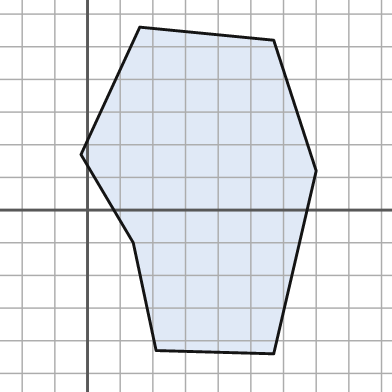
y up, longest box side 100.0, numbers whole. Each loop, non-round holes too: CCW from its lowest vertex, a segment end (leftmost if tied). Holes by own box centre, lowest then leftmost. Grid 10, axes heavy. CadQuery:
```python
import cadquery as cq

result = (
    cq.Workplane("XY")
    .moveTo(57.0, -44.0)
    .lineTo(70.0, 12.0)
    .lineTo(57.0, 52.0)
    .lineTo(16.0, 56.0)
    .lineTo(-2.0, 17.0)
    .lineTo(14.0, -10.0)
    .lineTo(21.0, -43.0)
    .close()
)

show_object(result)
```